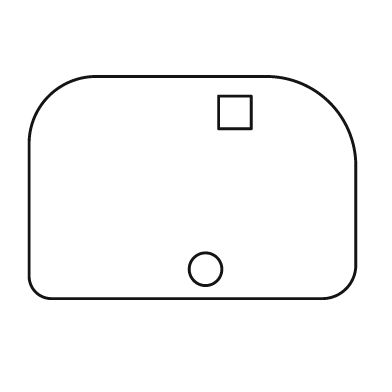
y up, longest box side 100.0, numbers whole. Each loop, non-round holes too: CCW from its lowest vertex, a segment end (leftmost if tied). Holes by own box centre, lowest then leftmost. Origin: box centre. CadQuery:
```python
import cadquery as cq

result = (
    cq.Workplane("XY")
    .moveTo(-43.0, -34.0)
    .lineTo(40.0, -34.0)
    .threePointArc((47.0, -31.0), (50.0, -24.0))
    .lineTo(50.0, 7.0)
    .threePointArc((42.0, 26.0), (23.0, 34.0))
    .lineTo(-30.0, 34.0)
    .threePointArc((-44.0, 28.0), (-50.0, 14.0))
    .lineTo(-50.0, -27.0)
    .threePointArc((-48.0, -32.0), (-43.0, -34.0))
    .close()
    .moveTo(4.0, -25.0)
    .circle(5.0)
    .moveTo(8.0, 18.0)
    .lineTo(18.0, 18.0)
    .lineTo(18.0, 28.0)
    .lineTo(8.0, 28.0)
    .close()
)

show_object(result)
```